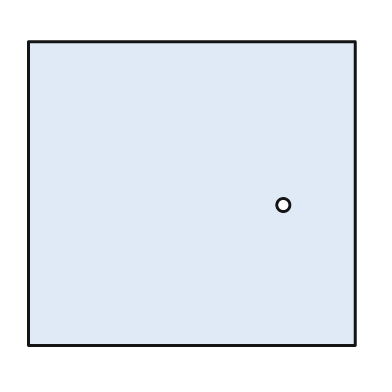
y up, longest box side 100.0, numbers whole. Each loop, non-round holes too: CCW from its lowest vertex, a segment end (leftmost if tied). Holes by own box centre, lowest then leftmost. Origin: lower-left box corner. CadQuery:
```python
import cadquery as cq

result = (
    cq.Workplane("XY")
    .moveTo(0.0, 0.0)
    .lineTo(100.0, 0.0)
    .lineTo(100.0, 93.0)
    .lineTo(0.0, 93.0)
    .close()
    .moveTo(78.0, 43.0)
    .circle(2.0)
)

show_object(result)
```